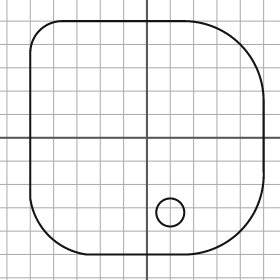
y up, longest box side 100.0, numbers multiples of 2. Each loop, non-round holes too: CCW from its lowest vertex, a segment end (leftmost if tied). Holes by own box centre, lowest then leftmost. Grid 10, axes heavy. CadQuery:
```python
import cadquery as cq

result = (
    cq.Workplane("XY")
    .moveTo(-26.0, -50.0)
    .lineTo(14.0, -50.0)
    .threePointArc((40.0, -40.0), (50.0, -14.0))
    .lineTo(50.0, 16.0)
    .threePointArc((40.0, 40.0), (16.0, 50.0))
    .lineTo(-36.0, 50.0)
    .threePointArc((-46.0, 46.0), (-50.0, 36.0))
    .lineTo(-50.0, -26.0)
    .threePointArc((-42.0, -42.0), (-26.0, -50.0))
    .close()
    .moveTo(10.0, -32.0)
    .circle(6.0)
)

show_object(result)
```